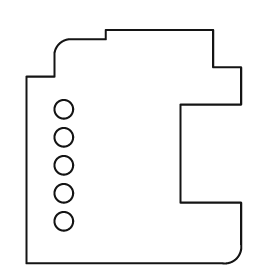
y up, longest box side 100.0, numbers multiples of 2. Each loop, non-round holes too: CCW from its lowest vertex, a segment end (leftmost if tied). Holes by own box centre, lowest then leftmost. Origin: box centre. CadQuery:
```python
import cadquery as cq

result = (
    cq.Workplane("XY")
    .moveTo(-46.0, -50.0)
    .lineTo(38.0, -50.0)
    .threePointArc((44.0, -48.0), (46.0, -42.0))
    .lineTo(46.0, -24.0)
    .lineTo(20.0, -24.0)
    .lineTo(20.0, 18.0)
    .lineTo(46.0, 18.0)
    .lineTo(46.0, 34.0)
    .lineTo(34.0, 34.0)
    .lineTo(34.0, 50.0)
    .lineTo(-12.0, 50.0)
    .lineTo(-12.0, 46.0)
    .lineTo(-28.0, 46.0)
    .threePointArc((-32.0, 44.0), (-34.0, 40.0))
    .lineTo(-34.0, 30.0)
    .lineTo(-46.0, 30.0)
    .close()
    .moveTo(-30.0, -32.0)
    .circle(4.0)
    .moveTo(-30.0, -20.0)
    .circle(4.0)
    .moveTo(-30.0, -8.0)
    .circle(4.0)
    .moveTo(-30.0, 4.0)
    .circle(4.0)
    .moveTo(-30.0, 16.0)
    .circle(4.0)
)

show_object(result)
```